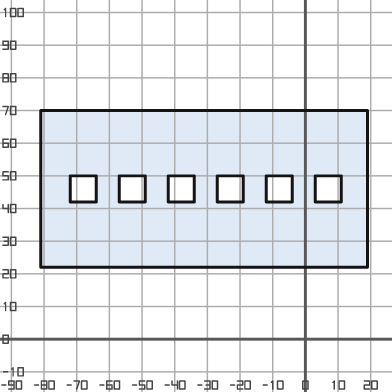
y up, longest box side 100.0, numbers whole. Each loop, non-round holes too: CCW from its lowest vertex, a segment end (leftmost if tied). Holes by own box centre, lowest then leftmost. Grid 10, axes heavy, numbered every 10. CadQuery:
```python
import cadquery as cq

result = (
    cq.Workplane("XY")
    .moveTo(-81.0, 22.0)
    .lineTo(19.0, 22.0)
    .lineTo(19.0, 70.0)
    .lineTo(-81.0, 70.0)
    .close()
    .moveTo(-72.0, 42.0)
    .lineTo(-64.0, 42.0)
    .lineTo(-64.0, 50.0)
    .lineTo(-72.0, 50.0)
    .close()
    .moveTo(-57.0, 42.0)
    .lineTo(-49.0, 42.0)
    .lineTo(-49.0, 50.0)
    .lineTo(-57.0, 50.0)
    .close()
    .moveTo(-42.0, 42.0)
    .lineTo(-34.0, 42.0)
    .lineTo(-34.0, 50.0)
    .lineTo(-42.0, 50.0)
    .close()
    .moveTo(-27.0, 42.0)
    .lineTo(-19.0, 42.0)
    .lineTo(-19.0, 50.0)
    .lineTo(-27.0, 50.0)
    .close()
    .moveTo(-12.0, 42.0)
    .lineTo(-4.0, 42.0)
    .lineTo(-4.0, 50.0)
    .lineTo(-12.0, 50.0)
    .close()
    .moveTo(3.0, 42.0)
    .lineTo(11.0, 42.0)
    .lineTo(11.0, 50.0)
    .lineTo(3.0, 50.0)
    .close()
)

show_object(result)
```